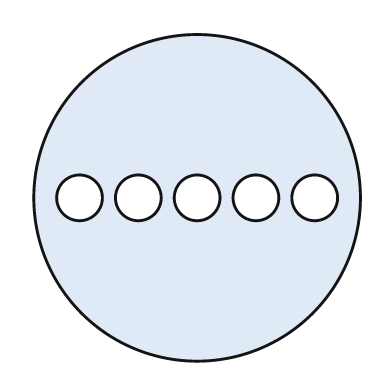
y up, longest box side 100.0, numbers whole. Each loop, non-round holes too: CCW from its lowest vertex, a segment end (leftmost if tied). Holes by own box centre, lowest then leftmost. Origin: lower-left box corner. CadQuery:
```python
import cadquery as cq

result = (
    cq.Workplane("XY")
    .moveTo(50.0, 50.0)
    .circle(50.0)
    .moveTo(14.0, 50.0)
    .circle(7.0)
    .moveTo(32.0, 50.0)
    .circle(7.0)
    .moveTo(50.0, 50.0)
    .circle(7.0)
    .moveTo(68.0, 50.0)
    .circle(7.0)
    .moveTo(86.0, 50.0)
    .circle(7.0)
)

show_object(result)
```